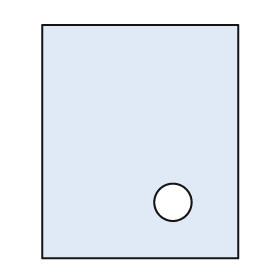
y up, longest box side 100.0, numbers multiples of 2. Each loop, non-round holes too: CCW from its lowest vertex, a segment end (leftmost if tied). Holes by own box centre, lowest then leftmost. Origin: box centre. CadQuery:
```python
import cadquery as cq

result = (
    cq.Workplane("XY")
    .moveTo(-42.0, -50.0)
    .lineTo(42.0, -50.0)
    .lineTo(42.0, 50.0)
    .lineTo(-42.0, 50.0)
    .close()
    .moveTo(14.0, -26.0)
    .circle(8.0)
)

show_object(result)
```